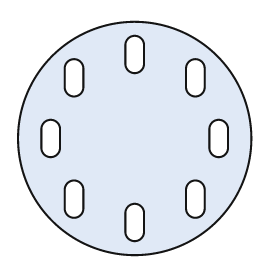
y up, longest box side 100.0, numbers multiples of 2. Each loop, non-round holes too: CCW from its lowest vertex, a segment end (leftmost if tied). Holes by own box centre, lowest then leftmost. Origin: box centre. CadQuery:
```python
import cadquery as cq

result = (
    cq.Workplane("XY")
    .moveTo(0.0, 0.0)
    .circle(50.0)
    .moveTo(-4.0, -40.0)
    .threePointArc((0.0, -44.0), (4.0, -40.0))
    .lineTo(4.0, -32.0)
    .threePointArc((0.0, -28.0), (-4.0, -32.0))
    .close()
    .moveTo(-30.0, -30.0)
    .threePointArc((-26.0, -34.0), (-22.0, -30.0))
    .lineTo(-22.0, -22.0)
    .threePointArc((-26.0, -18.0), (-30.0, -22.0))
    .close()
    .moveTo(22.0, -30.0)
    .threePointArc((26.0, -34.0), (30.0, -30.0))
    .lineTo(30.0, -22.0)
    .threePointArc((26.0, -18.0), (22.0, -22.0))
    .close()
    .moveTo(-40.0, -4.0)
    .threePointArc((-36.0, -8.0), (-32.0, -4.0))
    .lineTo(-32.0, 4.0)
    .threePointArc((-36.0, 8.0), (-40.0, 4.0))
    .close()
    .moveTo(32.0, -4.0)
    .threePointArc((36.0, -8.0), (40.0, -4.0))
    .lineTo(40.0, 4.0)
    .threePointArc((36.0, 8.0), (32.0, 4.0))
    .close()
    .moveTo(-30.0, 22.0)
    .threePointArc((-26.0, 18.0), (-22.0, 22.0))
    .lineTo(-22.0, 30.0)
    .threePointArc((-26.0, 34.0), (-30.0, 30.0))
    .close()
    .moveTo(22.0, 22.0)
    .threePointArc((26.0, 18.0), (30.0, 22.0))
    .lineTo(30.0, 30.0)
    .threePointArc((26.0, 34.0), (22.0, 30.0))
    .close()
    .moveTo(-4.0, 32.0)
    .threePointArc((0.0, 28.0), (4.0, 32.0))
    .lineTo(4.0, 40.0)
    .threePointArc((0.0, 44.0), (-4.0, 40.0))
    .close()
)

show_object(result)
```